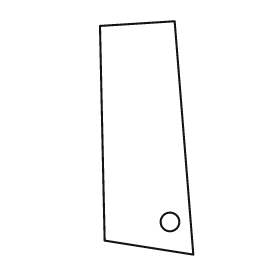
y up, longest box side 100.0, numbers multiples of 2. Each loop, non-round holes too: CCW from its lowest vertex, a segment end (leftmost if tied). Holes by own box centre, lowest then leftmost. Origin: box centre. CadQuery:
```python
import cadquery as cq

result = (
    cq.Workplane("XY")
    .moveTo(20.0, -50.0)
    .lineTo(12.0, 50.0)
    .lineTo(-20.0, 48.0)
    .lineTo(-18.0, -44.0)
    .close()
    .moveTo(10.0, -36.0)
    .circle(4.0)
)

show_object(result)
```